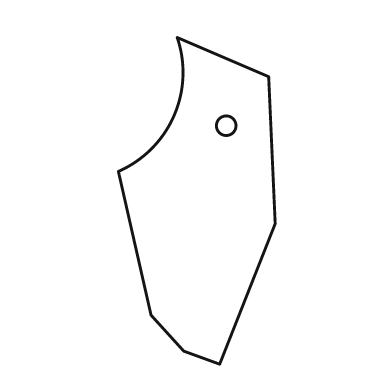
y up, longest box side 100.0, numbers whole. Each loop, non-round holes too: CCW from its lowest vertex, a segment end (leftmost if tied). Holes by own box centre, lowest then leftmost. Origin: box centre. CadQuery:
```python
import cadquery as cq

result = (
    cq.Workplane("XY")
    .moveTo(7.0, -50.0)
    .lineTo(24.0, -7.0)
    .lineTo(22.0, 38.0)
    .lineTo(-6.0, 50.0)
    .threePointArc((-7.0, 26.0), (-24.0, 9.0))
    .lineTo(-14.0, -35.0)
    .lineTo(-4.0, -46.0)
    .close()
    .moveTo(9.0, 23.0)
    .circle(3.0)
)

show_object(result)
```